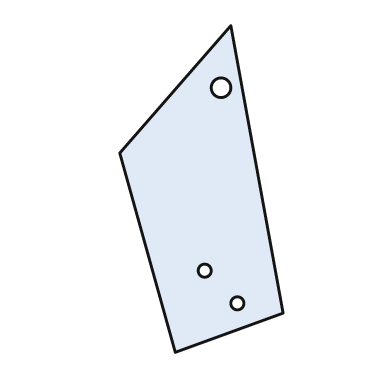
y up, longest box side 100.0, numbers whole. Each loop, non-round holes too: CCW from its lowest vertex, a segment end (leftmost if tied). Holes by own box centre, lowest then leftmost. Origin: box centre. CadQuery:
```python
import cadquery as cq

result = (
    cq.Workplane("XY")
    .moveTo(-8.0, -50.0)
    .lineTo(25.0, -38.0)
    .lineTo(9.0, 50.0)
    .lineTo(-25.0, 11.0)
    .close()
    .moveTo(11.0, -35.0)
    .circle(2.0)
    .moveTo(1.0, -25.0)
    .circle(2.0)
    .moveTo(6.0, 31.0)
    .circle(3.0)
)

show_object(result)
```